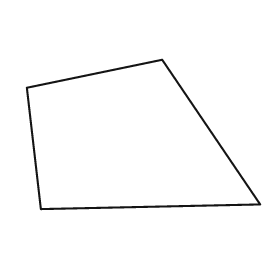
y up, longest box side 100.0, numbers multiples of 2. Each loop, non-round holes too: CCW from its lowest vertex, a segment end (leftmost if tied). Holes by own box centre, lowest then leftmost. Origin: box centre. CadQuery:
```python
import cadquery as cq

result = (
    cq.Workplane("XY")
    .moveTo(-44.0, -32.0)
    .lineTo(50.0, -30.0)
    .lineTo(8.0, 32.0)
    .lineTo(-50.0, 20.0)
    .close()
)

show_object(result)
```